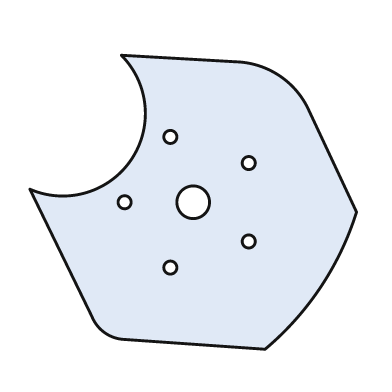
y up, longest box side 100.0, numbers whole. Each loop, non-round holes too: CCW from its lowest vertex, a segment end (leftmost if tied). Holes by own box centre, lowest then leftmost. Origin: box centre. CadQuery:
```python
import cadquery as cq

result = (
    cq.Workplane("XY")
    .moveTo(22.0, -45.0)
    .threePointArc((39.0, -26.0), (50.0, -3.0))
    .lineTo(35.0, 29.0)
    .threePointArc((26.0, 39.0), (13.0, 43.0))
    .lineTo(-22.0, 45.0)
    .threePointArc((-19.0, 13.0), (-50.0, 4.0))
    .lineTo(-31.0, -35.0)
    .threePointArc((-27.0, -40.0), (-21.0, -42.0))
    .close()
    .moveTo(-7.0, -20.0)
    .circle(2.0)
    .moveTo(17.0, -12.0)
    .circle(2.0)
    .moveTo(-21.0, 0.0)
    .circle(2.0)
    .moveTo(0.0, 0.0)
    .circle(5.0)
    .moveTo(17.0, 12.0)
    .circle(2.0)
    .moveTo(-7.0, 20.0)
    .circle(2.0)
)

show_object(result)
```